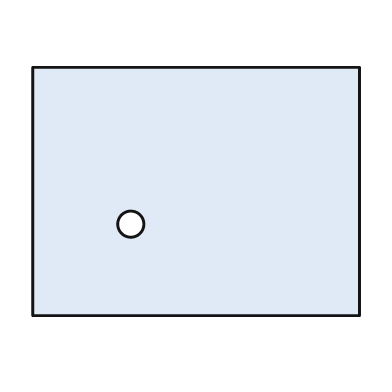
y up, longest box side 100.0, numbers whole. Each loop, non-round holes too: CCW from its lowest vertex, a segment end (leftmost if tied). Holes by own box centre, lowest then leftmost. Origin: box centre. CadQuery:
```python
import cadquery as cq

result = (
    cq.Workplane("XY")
    .moveTo(-50.0, -38.0)
    .lineTo(50.0, -38.0)
    .lineTo(50.0, 38.0)
    .lineTo(-50.0, 38.0)
    .close()
    .moveTo(-20.0, -10.0)
    .circle(4.0)
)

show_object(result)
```